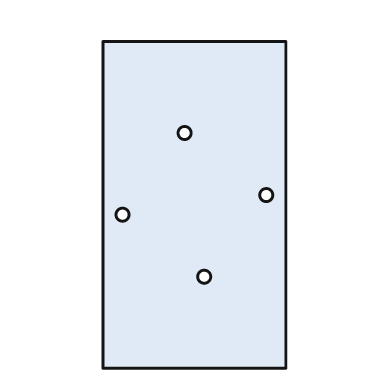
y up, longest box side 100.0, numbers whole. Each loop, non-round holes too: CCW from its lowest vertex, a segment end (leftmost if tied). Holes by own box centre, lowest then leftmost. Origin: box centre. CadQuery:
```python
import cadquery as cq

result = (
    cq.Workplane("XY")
    .moveTo(-28.0, -50.0)
    .lineTo(28.0, -50.0)
    .lineTo(28.0, 50.0)
    .lineTo(-28.0, 50.0)
    .close()
    .moveTo(3.0, -22.0)
    .circle(2.0)
    .moveTo(-22.0, -3.0)
    .circle(2.0)
    .moveTo(22.0, 3.0)
    .circle(2.0)
    .moveTo(-3.0, 22.0)
    .circle(2.0)
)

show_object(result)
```